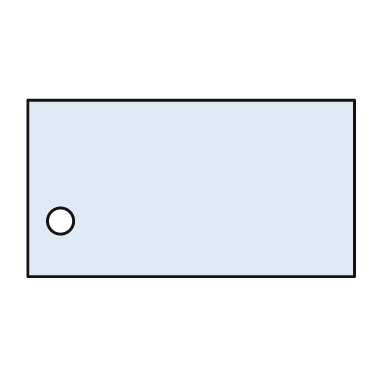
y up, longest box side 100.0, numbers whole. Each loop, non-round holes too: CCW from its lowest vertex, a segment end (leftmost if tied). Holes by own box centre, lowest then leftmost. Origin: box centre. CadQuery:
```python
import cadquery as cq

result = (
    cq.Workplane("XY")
    .moveTo(-50.0, -27.0)
    .lineTo(50.0, -27.0)
    .lineTo(50.0, 27.0)
    .lineTo(-50.0, 27.0)
    .close()
    .moveTo(-40.0, -10.0)
    .circle(4.0)
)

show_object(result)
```